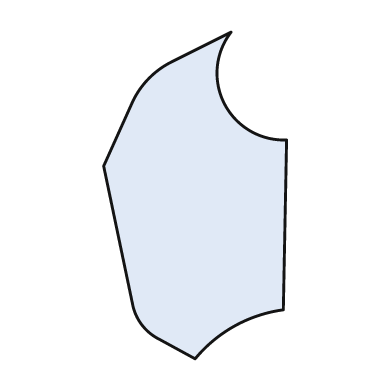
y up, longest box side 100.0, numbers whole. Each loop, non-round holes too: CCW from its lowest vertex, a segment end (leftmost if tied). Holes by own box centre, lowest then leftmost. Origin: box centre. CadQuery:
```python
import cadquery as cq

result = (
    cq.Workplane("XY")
    .moveTo(0.0, -50.0)
    .threePointArc((12.0, -40.0), (27.0, -35.0))
    .lineTo(28.0, 17.0)
    .threePointArc((9.0, 28.0), (11.0, 50.0))
    .lineTo(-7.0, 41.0)
    .threePointArc((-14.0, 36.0), (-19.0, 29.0))
    .lineTo(-28.0, 9.0)
    .lineTo(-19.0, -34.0)
    .threePointArc((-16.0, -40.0), (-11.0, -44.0))
    .close()
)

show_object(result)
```